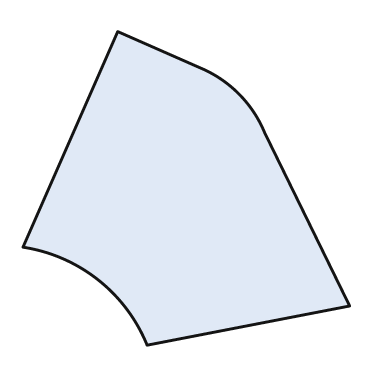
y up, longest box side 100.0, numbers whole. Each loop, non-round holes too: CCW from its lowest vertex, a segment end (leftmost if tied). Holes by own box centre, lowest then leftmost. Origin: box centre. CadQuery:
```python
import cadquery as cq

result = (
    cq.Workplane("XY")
    .moveTo(-12.0, -48.0)
    .lineTo(50.0, -36.0)
    .lineTo(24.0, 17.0)
    .threePointArc((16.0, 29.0), (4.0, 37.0))
    .lineTo(-21.0, 48.0)
    .lineTo(-50.0, -18.0)
    .threePointArc((-27.0, -28.0), (-12.0, -48.0))
    .close()
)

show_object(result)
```